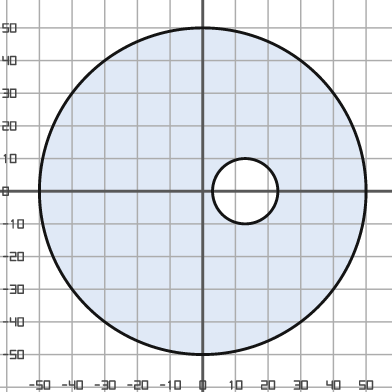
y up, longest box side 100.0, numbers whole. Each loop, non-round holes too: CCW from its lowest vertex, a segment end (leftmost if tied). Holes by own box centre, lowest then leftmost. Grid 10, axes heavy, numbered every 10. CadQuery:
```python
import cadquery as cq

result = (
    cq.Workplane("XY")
    .moveTo(0.0, 0.0)
    .circle(50.0)
    .moveTo(13.0, 0.0)
    .circle(10.0)
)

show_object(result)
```